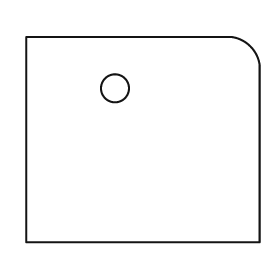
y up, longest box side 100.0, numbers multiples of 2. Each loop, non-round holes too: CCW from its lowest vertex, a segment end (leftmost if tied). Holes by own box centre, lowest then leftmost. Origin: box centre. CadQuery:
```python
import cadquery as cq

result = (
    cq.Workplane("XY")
    .moveTo(-50.0, -44.0)
    .lineTo(50.0, -44.0)
    .lineTo(50.0, 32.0)
    .threePointArc((46.0, 40.0), (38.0, 44.0))
    .lineTo(-50.0, 44.0)
    .close()
    .moveTo(-12.0, 22.0)
    .circle(6.0)
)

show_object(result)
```